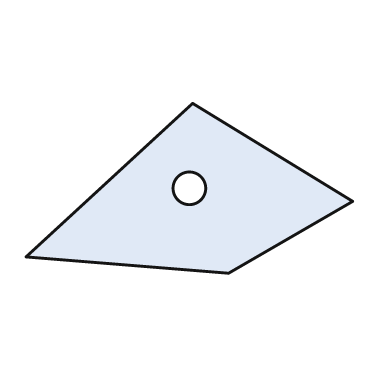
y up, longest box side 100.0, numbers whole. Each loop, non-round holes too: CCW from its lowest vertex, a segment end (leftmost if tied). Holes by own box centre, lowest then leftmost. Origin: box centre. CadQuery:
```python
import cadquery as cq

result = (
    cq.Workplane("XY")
    .moveTo(12.0, -26.0)
    .lineTo(50.0, -4.0)
    .lineTo(1.0, 26.0)
    .lineTo(-50.0, -21.0)
    .close()
    .moveTo(0.0, 0.0)
    .circle(5.0)
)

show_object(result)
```